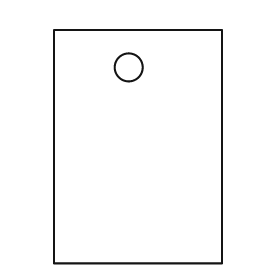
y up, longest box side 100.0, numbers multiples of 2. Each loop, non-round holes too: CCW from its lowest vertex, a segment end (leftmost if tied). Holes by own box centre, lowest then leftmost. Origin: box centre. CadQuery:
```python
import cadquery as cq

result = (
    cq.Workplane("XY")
    .moveTo(-36.0, -50.0)
    .lineTo(36.0, -50.0)
    .lineTo(36.0, 50.0)
    .lineTo(-36.0, 50.0)
    .close()
    .moveTo(-4.0, 34.0)
    .circle(6.0)
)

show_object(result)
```